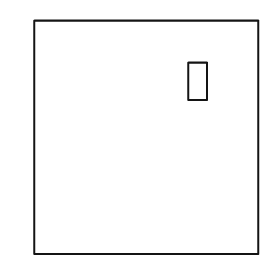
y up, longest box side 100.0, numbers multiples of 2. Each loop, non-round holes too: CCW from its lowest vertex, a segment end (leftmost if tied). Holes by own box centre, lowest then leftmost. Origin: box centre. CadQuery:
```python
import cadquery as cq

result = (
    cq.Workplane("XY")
    .moveTo(-48.0, -50.0)
    .lineTo(48.0, -50.0)
    .lineTo(48.0, 50.0)
    .lineTo(-48.0, 50.0)
    .close()
    .moveTo(18.0, 16.0)
    .lineTo(26.0, 16.0)
    .lineTo(26.0, 32.0)
    .lineTo(18.0, 32.0)
    .close()
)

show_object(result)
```